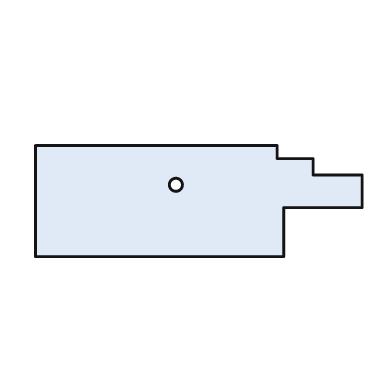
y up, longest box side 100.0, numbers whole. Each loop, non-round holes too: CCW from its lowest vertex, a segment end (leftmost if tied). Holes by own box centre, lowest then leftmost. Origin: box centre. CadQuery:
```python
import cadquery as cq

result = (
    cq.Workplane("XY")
    .moveTo(-50.0, -17.0)
    .lineTo(26.0, -17.0)
    .lineTo(26.0, -2.0)
    .lineTo(50.0, -2.0)
    .lineTo(50.0, 8.0)
    .lineTo(35.0, 8.0)
    .lineTo(35.0, 13.0)
    .lineTo(24.0, 13.0)
    .lineTo(24.0, 17.0)
    .lineTo(-50.0, 17.0)
    .close()
    .moveTo(-7.0, 5.0)
    .circle(2.0)
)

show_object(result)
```